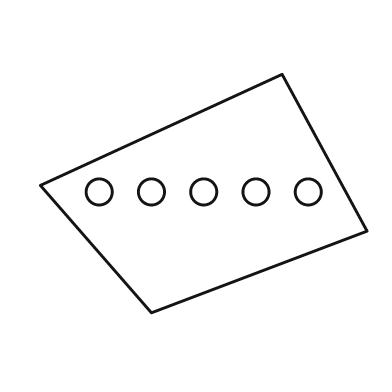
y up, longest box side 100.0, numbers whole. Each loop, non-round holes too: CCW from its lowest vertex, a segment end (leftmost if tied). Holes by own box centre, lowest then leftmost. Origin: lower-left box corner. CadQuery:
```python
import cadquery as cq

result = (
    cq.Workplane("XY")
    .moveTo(34.0, 0.0)
    .lineTo(100.0, 25.0)
    .lineTo(74.0, 73.0)
    .lineTo(0.0, 39.0)
    .close()
    .moveTo(18.0, 37.0)
    .circle(4.0)
    .moveTo(34.0, 37.0)
    .circle(4.0)
    .moveTo(50.0, 37.0)
    .circle(4.0)
    .moveTo(66.0, 37.0)
    .circle(4.0)
    .moveTo(82.0, 37.0)
    .circle(4.0)
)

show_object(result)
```